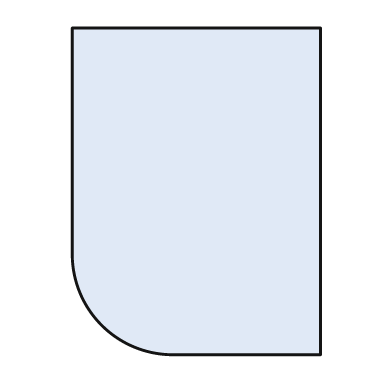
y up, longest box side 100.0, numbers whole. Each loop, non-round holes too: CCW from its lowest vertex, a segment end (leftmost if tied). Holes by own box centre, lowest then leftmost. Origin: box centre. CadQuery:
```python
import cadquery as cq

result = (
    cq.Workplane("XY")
    .moveTo(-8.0, -50.0)
    .lineTo(38.0, -50.0)
    .lineTo(38.0, 50.0)
    .lineTo(-38.0, 50.0)
    .lineTo(-38.0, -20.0)
    .threePointArc((-29.0, -41.0), (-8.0, -50.0))
    .close()
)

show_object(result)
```